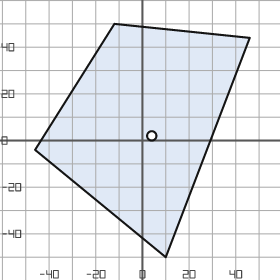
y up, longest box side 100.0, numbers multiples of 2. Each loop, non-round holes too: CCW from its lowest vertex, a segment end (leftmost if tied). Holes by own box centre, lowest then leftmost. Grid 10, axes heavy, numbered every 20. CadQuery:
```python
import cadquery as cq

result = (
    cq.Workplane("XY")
    .moveTo(10.0, -50.0)
    .lineTo(46.0, 44.0)
    .lineTo(-12.0, 50.0)
    .lineTo(-46.0, -4.0)
    .close()
    .moveTo(4.0, 2.0)
    .circle(2.0)
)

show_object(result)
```